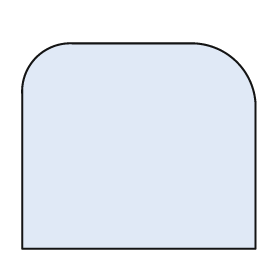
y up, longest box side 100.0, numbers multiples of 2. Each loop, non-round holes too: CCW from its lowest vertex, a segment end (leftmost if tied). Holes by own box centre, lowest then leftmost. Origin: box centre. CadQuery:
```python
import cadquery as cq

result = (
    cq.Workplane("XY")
    .moveTo(-50.0, -44.0)
    .lineTo(50.0, -44.0)
    .lineTo(50.0, 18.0)
    .threePointArc((42.0, 36.0), (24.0, 44.0))
    .lineTo(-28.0, 44.0)
    .threePointArc((-44.0, 38.0), (-50.0, 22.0))
    .close()
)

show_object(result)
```